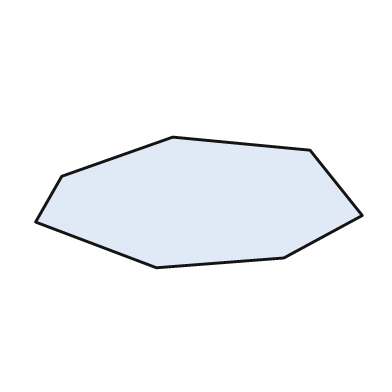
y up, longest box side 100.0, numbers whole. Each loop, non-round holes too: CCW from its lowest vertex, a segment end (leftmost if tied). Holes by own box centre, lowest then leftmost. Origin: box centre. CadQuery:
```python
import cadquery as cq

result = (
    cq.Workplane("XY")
    .moveTo(-13.0, -20.0)
    .lineTo(26.0, -17.0)
    .lineTo(50.0, -4.0)
    .lineTo(34.0, 16.0)
    .lineTo(-8.0, 20.0)
    .lineTo(-42.0, 8.0)
    .lineTo(-50.0, -6.0)
    .close()
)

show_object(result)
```